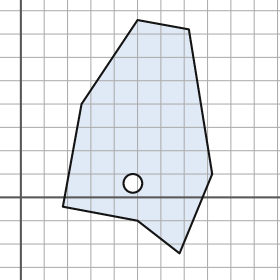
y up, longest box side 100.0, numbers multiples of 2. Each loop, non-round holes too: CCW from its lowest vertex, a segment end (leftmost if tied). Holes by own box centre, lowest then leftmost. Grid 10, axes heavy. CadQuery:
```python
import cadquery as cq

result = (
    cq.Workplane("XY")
    .moveTo(68.0, -24.0)
    .lineTo(82.0, 10.0)
    .lineTo(72.0, 72.0)
    .lineTo(50.0, 76.0)
    .lineTo(26.0, 40.0)
    .lineTo(18.0, -4.0)
    .lineTo(50.0, -10.0)
    .close()
    .moveTo(48.0, 6.0)
    .circle(4.0)
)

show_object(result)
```